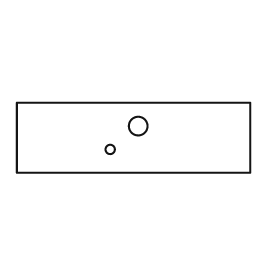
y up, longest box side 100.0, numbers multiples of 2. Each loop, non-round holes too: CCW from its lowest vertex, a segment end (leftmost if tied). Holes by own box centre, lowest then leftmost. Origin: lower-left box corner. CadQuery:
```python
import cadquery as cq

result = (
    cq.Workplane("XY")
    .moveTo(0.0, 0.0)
    .lineTo(100.0, 0.0)
    .lineTo(100.0, 30.0)
    .lineTo(0.0, 30.0)
    .close()
    .moveTo(40.0, 10.0)
    .circle(2.0)
    .moveTo(52.0, 20.0)
    .circle(4.0)
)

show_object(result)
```